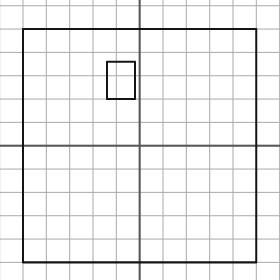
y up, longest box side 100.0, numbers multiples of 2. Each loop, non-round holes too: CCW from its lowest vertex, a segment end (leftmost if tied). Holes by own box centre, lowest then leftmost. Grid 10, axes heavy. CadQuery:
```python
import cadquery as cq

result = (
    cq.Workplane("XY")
    .moveTo(-50.0, -50.0)
    .lineTo(50.0, -50.0)
    .lineTo(50.0, 50.0)
    .lineTo(-50.0, 50.0)
    .close()
    .moveTo(-14.0, 20.0)
    .lineTo(-2.0, 20.0)
    .lineTo(-2.0, 36.0)
    .lineTo(-14.0, 36.0)
    .close()
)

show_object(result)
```